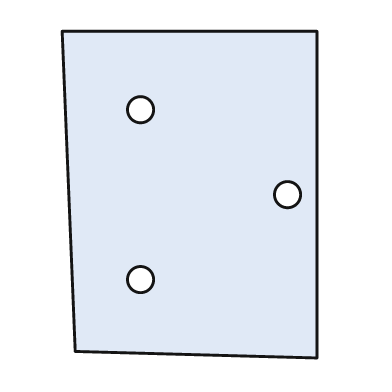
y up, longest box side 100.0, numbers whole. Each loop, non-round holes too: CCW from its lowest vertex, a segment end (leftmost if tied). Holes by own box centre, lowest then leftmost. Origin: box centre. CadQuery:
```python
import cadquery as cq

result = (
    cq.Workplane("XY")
    .moveTo(39.0, -50.0)
    .lineTo(39.0, 50.0)
    .lineTo(-39.0, 50.0)
    .lineTo(-35.0, -48.0)
    .close()
    .moveTo(-15.0, -26.0)
    .circle(4.0)
    .moveTo(30.0, 0.0)
    .circle(4.0)
    .moveTo(-15.0, 26.0)
    .circle(4.0)
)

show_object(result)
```